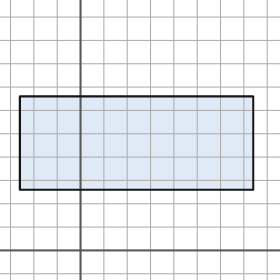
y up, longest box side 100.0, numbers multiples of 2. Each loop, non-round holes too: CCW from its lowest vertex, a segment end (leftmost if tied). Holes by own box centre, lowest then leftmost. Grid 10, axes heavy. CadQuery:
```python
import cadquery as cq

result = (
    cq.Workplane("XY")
    .moveTo(-26.0, 26.0)
    .lineTo(74.0, 26.0)
    .lineTo(74.0, 66.0)
    .lineTo(-26.0, 66.0)
    .close()
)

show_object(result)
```